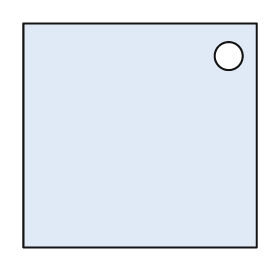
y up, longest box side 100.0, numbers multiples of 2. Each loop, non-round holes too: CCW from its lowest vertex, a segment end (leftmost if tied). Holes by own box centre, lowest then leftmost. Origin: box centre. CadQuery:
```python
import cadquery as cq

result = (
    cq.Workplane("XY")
    .moveTo(-50.0, -48.0)
    .lineTo(50.0, -48.0)
    .lineTo(50.0, 48.0)
    .lineTo(-50.0, 48.0)
    .close()
    .moveTo(38.0, 34.0)
    .circle(6.0)
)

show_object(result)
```